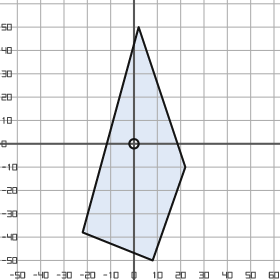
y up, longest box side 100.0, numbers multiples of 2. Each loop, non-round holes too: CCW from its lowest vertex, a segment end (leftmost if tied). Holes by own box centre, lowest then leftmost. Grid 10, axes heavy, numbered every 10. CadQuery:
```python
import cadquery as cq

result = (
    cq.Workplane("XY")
    .moveTo(8.0, -50.0)
    .lineTo(22.0, -10.0)
    .lineTo(2.0, 50.0)
    .lineTo(-22.0, -38.0)
    .close()
    .moveTo(0.0, 0.0)
    .circle(2.0)
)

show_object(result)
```